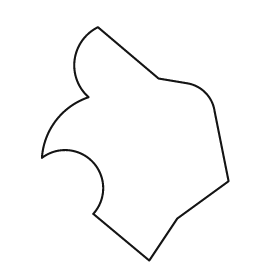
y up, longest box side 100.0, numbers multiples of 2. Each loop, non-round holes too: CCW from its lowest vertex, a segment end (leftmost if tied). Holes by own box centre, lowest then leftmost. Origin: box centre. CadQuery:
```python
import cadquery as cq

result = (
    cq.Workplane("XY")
    .moveTo(6.0, -50.0)
    .lineTo(18.0, -32.0)
    .lineTo(40.0, -16.0)
    .lineTo(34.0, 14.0)
    .threePointArc((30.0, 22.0), (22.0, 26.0))
    .lineTo(10.0, 28.0)
    .lineTo(-16.0, 50.0)
    .threePointArc((-26.0, 36.0), (-20.0, 20.0))
    .threePointArc((-34.0, 10.0), (-40.0, -6.0))
    .threePointArc((-18.0, -8.0), (-18.0, -30.0))
    .close()
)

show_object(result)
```